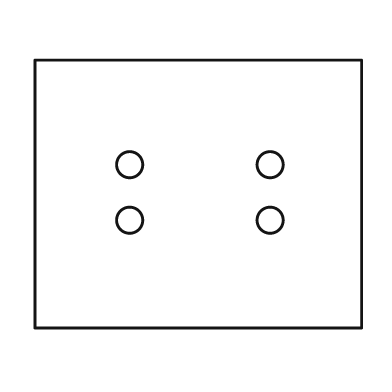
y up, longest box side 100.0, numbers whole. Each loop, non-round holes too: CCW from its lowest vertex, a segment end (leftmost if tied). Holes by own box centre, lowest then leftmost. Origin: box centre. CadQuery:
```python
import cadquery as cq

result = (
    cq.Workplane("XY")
    .moveTo(-50.0, -41.0)
    .lineTo(50.0, -41.0)
    .lineTo(50.0, 41.0)
    .lineTo(-50.0, 41.0)
    .close()
    .moveTo(-21.0, -8.0)
    .circle(4.0)
    .moveTo(22.0, -8.0)
    .circle(4.0)
    .moveTo(-21.0, 9.0)
    .circle(4.0)
    .moveTo(22.0, 9.0)
    .circle(4.0)
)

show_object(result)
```